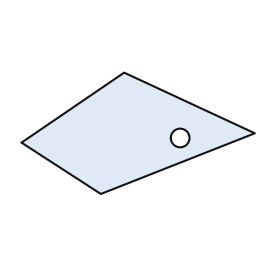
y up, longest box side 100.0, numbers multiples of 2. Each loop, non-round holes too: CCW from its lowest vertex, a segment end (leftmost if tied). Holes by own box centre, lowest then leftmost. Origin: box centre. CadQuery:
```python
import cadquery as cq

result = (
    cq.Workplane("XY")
    .moveTo(-16.0, -26.0)
    .lineTo(50.0, 0.0)
    .lineTo(-6.0, 26.0)
    .lineTo(-50.0, -4.0)
    .close()
    .moveTo(18.0, -2.0)
    .circle(4.0)
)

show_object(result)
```